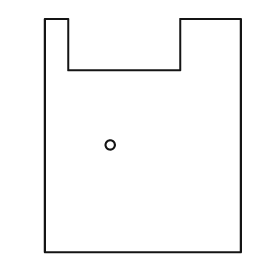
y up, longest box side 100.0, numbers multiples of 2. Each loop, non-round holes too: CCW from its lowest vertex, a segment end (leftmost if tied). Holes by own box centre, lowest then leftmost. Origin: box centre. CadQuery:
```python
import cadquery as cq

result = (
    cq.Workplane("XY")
    .moveTo(-42.0, -50.0)
    .lineTo(42.0, -50.0)
    .lineTo(42.0, 50.0)
    .lineTo(16.0, 50.0)
    .lineTo(16.0, 28.0)
    .lineTo(-32.0, 28.0)
    .lineTo(-32.0, 50.0)
    .lineTo(-42.0, 50.0)
    .close()
    .moveTo(-14.0, -4.0)
    .circle(2.0)
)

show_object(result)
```